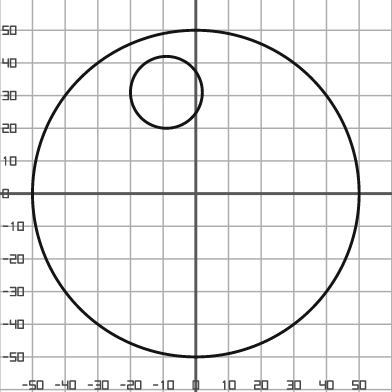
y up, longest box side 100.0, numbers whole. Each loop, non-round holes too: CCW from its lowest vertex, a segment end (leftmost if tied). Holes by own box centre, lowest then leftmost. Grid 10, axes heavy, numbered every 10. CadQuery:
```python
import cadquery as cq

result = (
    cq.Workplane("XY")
    .moveTo(0.0, 0.0)
    .circle(50.0)
    .moveTo(-9.0, 31.0)
    .circle(11.0)
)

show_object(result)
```